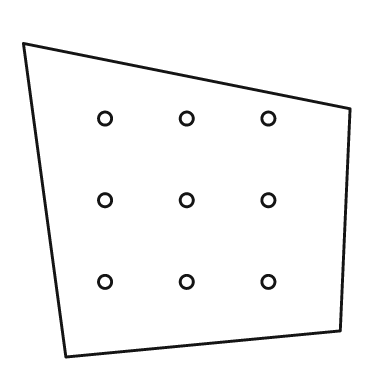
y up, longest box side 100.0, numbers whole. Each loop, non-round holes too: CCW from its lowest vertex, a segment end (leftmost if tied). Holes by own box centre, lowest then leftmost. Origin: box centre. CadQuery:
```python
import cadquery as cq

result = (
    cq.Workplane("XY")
    .moveTo(-37.0, -48.0)
    .lineTo(47.0, -40.0)
    .lineTo(50.0, 28.0)
    .lineTo(-50.0, 48.0)
    .close()
    .moveTo(-25.0, -25.0)
    .circle(2.0)
    .moveTo(0.0, -25.0)
    .circle(2.0)
    .moveTo(25.0, -25.0)
    .circle(2.0)
    .moveTo(-25.0, 0.0)
    .circle(2.0)
    .moveTo(0.0, 0.0)
    .circle(2.0)
    .moveTo(25.0, 0.0)
    .circle(2.0)
    .moveTo(-25.0, 25.0)
    .circle(2.0)
    .moveTo(0.0, 25.0)
    .circle(2.0)
    .moveTo(25.0, 25.0)
    .circle(2.0)
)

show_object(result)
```